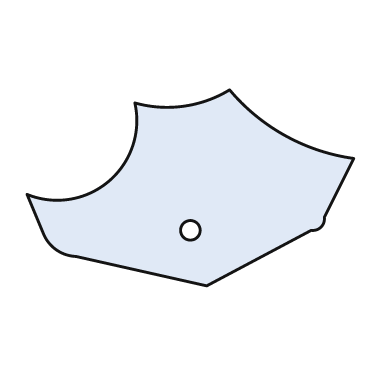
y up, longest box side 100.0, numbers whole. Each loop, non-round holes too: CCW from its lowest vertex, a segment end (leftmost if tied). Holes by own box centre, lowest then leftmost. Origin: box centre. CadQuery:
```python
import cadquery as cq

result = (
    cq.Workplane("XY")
    .moveTo(5.0, -30.0)
    .lineTo(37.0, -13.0)
    .threePointArc((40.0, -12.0), (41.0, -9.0))
    .lineTo(50.0, 9.0)
    .threePointArc((29.0, 16.0), (12.0, 30.0))
    .threePointArc((-2.0, 25.0), (-17.0, 26.0))
    .threePointArc((-25.0, 2.0), (-50.0, -2.0))
    .lineTo(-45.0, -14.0)
    .threePointArc((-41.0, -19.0), (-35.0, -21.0))
    .close()
    .moveTo(0.0, -13.0)
    .circle(3.0)
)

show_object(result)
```